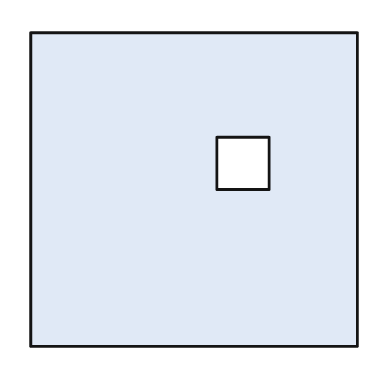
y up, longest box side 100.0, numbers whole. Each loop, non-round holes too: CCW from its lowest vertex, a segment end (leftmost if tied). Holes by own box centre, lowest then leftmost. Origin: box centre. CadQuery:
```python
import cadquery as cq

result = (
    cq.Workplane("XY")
    .moveTo(-50.0, -48.0)
    .lineTo(50.0, -48.0)
    .lineTo(50.0, 48.0)
    .lineTo(-50.0, 48.0)
    .close()
    .moveTo(7.0, 0.0)
    .lineTo(23.0, 0.0)
    .lineTo(23.0, 16.0)
    .lineTo(7.0, 16.0)
    .close()
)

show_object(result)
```